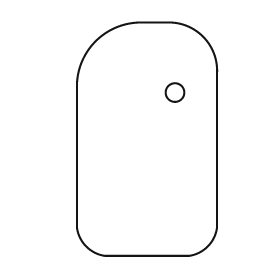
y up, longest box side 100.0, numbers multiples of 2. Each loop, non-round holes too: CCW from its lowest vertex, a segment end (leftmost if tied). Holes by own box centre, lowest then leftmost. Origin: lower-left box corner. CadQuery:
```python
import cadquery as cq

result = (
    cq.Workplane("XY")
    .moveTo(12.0, 0.0)
    .lineTo(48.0, 0.0)
    .threePointArc((56.0, 4.0), (60.0, 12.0))
    .lineTo(60.0, 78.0)
    .threePointArc((54.0, 94.0), (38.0, 100.0))
    .lineTo(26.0, 100.0)
    .threePointArc((8.0, 92.0), (0.0, 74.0))
    .lineTo(0.0, 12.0)
    .threePointArc((4.0, 4.0), (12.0, 0.0))
    .close()
    .moveTo(42.0, 70.0)
    .circle(4.0)
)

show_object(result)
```